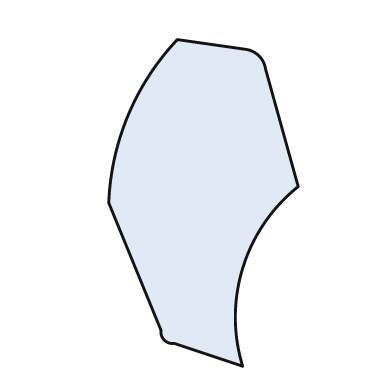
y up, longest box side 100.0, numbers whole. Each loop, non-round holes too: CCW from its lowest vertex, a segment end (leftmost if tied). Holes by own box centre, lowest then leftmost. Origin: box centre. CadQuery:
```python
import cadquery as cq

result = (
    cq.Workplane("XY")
    .moveTo(12.0, -50.0)
    .threePointArc((12.0, -20.0), (29.0, 5.0))
    .lineTo(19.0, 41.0)
    .threePointArc((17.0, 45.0), (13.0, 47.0))
    .lineTo(-8.0, 50.0)
    .threePointArc((-23.0, 27.0), (-29.0, 0.0))
    .lineTo(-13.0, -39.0)
    .threePointArc((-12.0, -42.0), (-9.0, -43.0))
    .close()
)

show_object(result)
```